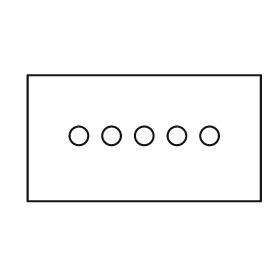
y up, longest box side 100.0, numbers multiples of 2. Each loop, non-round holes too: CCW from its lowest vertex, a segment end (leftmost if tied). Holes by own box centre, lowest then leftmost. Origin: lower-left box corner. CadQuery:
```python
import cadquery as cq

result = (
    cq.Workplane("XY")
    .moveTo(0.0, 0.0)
    .lineTo(100.0, 0.0)
    .lineTo(100.0, 54.0)
    .lineTo(0.0, 54.0)
    .close()
    .moveTo(22.0, 28.0)
    .circle(4.0)
    .moveTo(36.0, 28.0)
    .circle(4.0)
    .moveTo(50.0, 28.0)
    .circle(4.0)
    .moveTo(64.0, 28.0)
    .circle(4.0)
    .moveTo(78.0, 28.0)
    .circle(4.0)
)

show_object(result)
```